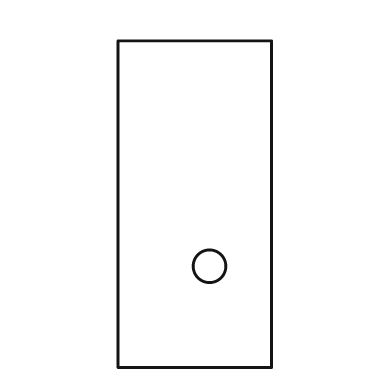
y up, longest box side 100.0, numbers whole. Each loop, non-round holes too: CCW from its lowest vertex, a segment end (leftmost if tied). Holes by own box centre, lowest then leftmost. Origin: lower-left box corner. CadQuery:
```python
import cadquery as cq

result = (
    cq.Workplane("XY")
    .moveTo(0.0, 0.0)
    .lineTo(47.0, 0.0)
    .lineTo(47.0, 100.0)
    .lineTo(0.0, 100.0)
    .close()
    .moveTo(28.0, 31.0)
    .circle(5.0)
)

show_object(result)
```